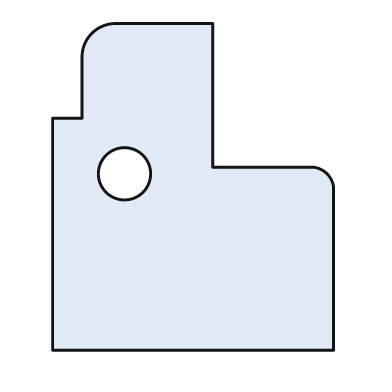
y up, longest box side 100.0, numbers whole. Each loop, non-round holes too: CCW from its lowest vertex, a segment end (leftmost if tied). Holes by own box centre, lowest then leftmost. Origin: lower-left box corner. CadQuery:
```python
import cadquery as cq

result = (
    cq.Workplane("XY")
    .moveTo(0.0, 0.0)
    .lineTo(86.0, 0.0)
    .lineTo(86.0, 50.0)
    .threePointArc((84.0, 54.0), (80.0, 56.0))
    .lineTo(49.0, 56.0)
    .lineTo(49.0, 100.0)
    .lineTo(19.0, 100.0)
    .threePointArc((12.0, 97.0), (9.0, 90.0))
    .lineTo(9.0, 71.0)
    .lineTo(0.0, 71.0)
    .close()
    .moveTo(22.0, 54.0)
    .circle(8.0)
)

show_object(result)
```